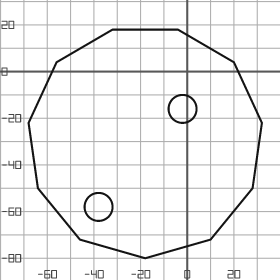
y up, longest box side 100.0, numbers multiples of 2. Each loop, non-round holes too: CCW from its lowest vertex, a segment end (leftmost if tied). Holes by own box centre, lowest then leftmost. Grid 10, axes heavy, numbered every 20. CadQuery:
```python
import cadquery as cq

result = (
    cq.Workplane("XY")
    .moveTo(-18.0, -80.0)
    .lineTo(10.0, -72.0)
    .lineTo(28.0, -50.0)
    .lineTo(32.0, -22.0)
    .lineTo(20.0, 4.0)
    .lineTo(-4.0, 18.0)
    .lineTo(-32.0, 18.0)
    .lineTo(-56.0, 4.0)
    .lineTo(-68.0, -22.0)
    .lineTo(-64.0, -50.0)
    .lineTo(-46.0, -72.0)
    .close()
    .moveTo(-38.0, -58.0)
    .circle(6.0)
    .moveTo(-2.0, -16.0)
    .circle(6.0)
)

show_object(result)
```